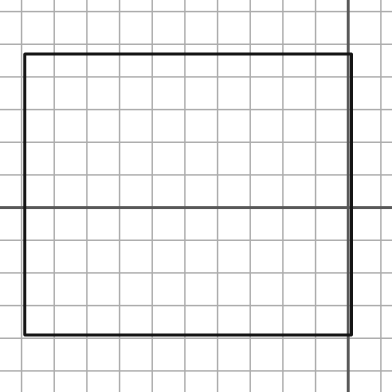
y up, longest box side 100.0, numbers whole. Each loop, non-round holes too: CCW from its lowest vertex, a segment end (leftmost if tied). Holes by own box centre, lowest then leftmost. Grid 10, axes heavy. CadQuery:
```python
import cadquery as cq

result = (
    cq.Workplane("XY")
    .moveTo(-99.0, -39.0)
    .lineTo(1.0, -39.0)
    .lineTo(1.0, 47.0)
    .lineTo(-99.0, 47.0)
    .close()
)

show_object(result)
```